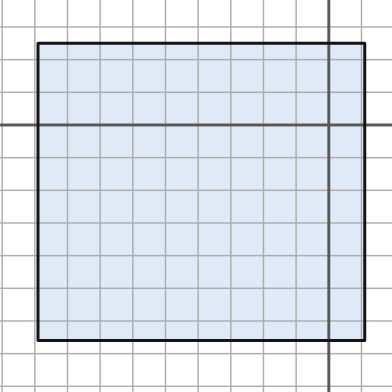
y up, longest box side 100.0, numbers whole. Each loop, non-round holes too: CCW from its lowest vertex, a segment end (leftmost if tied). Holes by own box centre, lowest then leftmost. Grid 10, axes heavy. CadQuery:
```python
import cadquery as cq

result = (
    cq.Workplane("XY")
    .moveTo(-89.0, -66.0)
    .lineTo(11.0, -66.0)
    .lineTo(11.0, 25.0)
    .lineTo(-89.0, 25.0)
    .close()
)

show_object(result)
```